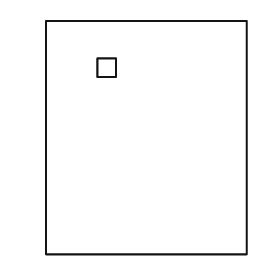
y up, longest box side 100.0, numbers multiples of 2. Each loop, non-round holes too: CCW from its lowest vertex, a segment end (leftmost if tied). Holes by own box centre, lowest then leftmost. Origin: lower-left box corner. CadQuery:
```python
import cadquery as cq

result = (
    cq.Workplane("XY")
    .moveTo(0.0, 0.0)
    .lineTo(86.0, 0.0)
    .lineTo(86.0, 100.0)
    .lineTo(0.0, 100.0)
    .close()
    .moveTo(22.0, 76.0)
    .lineTo(30.0, 76.0)
    .lineTo(30.0, 84.0)
    .lineTo(22.0, 84.0)
    .close()
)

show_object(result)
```